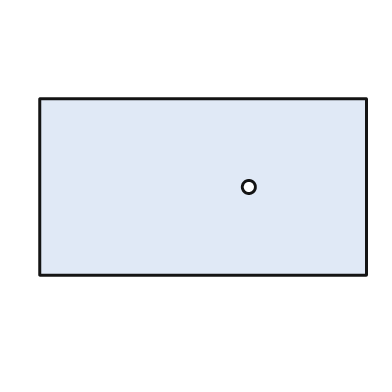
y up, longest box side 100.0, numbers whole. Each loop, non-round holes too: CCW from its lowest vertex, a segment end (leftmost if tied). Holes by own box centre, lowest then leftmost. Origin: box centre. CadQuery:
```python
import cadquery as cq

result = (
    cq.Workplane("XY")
    .moveTo(-50.0, -27.0)
    .lineTo(50.0, -27.0)
    .lineTo(50.0, 27.0)
    .lineTo(-50.0, 27.0)
    .close()
    .moveTo(14.0, 0.0)
    .circle(2.0)
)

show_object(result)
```